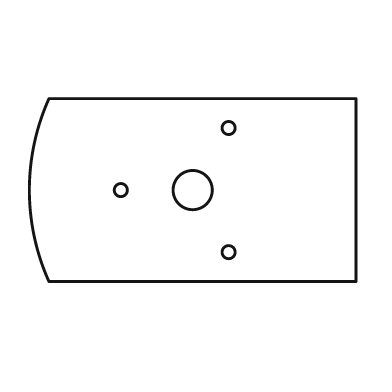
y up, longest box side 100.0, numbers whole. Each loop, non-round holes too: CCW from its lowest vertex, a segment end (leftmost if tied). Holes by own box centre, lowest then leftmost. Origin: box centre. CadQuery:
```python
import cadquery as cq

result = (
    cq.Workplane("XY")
    .moveTo(-44.0, -28.0)
    .lineTo(50.0, -28.0)
    .lineTo(50.0, 28.0)
    .lineTo(-44.0, 28.0)
    .threePointArc((-50.0, 0.0), (-44.0, -28.0))
    .close()
    .moveTo(11.0, -19.0)
    .circle(2.0)
    .moveTo(-22.0, 0.0)
    .circle(2.0)
    .moveTo(0.0, 0.0)
    .circle(6.0)
    .moveTo(11.0, 19.0)
    .circle(2.0)
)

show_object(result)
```